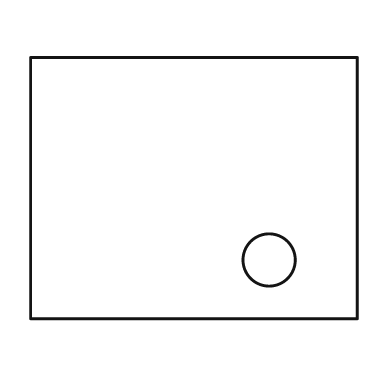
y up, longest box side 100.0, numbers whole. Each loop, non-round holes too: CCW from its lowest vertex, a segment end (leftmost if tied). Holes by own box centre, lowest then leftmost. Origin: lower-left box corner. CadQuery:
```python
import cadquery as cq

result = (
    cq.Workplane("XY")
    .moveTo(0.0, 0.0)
    .lineTo(100.0, 0.0)
    .lineTo(100.0, 80.0)
    .lineTo(0.0, 80.0)
    .close()
    .moveTo(73.0, 18.0)
    .circle(8.0)
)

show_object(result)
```